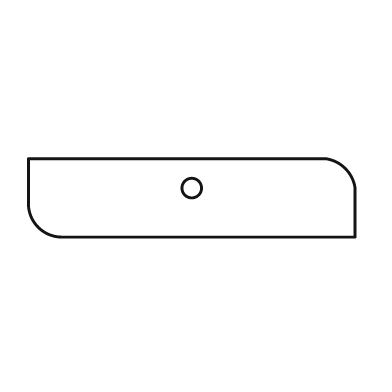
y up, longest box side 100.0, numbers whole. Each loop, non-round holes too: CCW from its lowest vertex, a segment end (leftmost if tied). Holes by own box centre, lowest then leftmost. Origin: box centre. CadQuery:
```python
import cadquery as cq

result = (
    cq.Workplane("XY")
    .moveTo(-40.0, -12.0)
    .lineTo(50.0, -12.0)
    .lineTo(50.0, 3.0)
    .threePointArc((47.0, 9.0), (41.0, 12.0))
    .lineTo(-50.0, 12.0)
    .lineTo(-50.0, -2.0)
    .threePointArc((-47.0, -9.0), (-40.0, -12.0))
    .close()
    .moveTo(0.0, 3.0)
    .circle(3.0)
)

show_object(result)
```